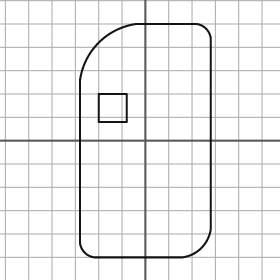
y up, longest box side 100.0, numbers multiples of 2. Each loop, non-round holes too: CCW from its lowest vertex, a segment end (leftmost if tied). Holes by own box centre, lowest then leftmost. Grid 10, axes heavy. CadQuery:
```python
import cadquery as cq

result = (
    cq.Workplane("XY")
    .moveTo(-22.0, -50.0)
    .lineTo(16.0, -50.0)
    .threePointArc((24.0, -46.0), (28.0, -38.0))
    .lineTo(28.0, 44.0)
    .threePointArc((26.0, 48.0), (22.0, 50.0))
    .lineTo(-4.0, 50.0)
    .threePointArc((-20.0, 42.0), (-28.0, 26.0))
    .lineTo(-28.0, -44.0)
    .threePointArc((-26.0, -48.0), (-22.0, -50.0))
    .close()
    .moveTo(-20.0, 8.0)
    .lineTo(-8.0, 8.0)
    .lineTo(-8.0, 20.0)
    .lineTo(-20.0, 20.0)
    .close()
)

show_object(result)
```